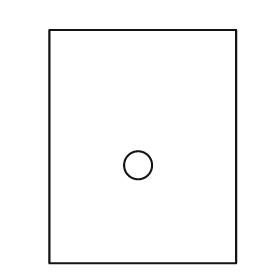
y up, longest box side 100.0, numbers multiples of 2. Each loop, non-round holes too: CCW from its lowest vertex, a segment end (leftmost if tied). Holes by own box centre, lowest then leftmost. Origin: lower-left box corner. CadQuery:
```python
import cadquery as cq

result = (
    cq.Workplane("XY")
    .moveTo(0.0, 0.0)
    .lineTo(80.0, 0.0)
    .lineTo(80.0, 100.0)
    .lineTo(0.0, 100.0)
    .close()
    .moveTo(38.0, 42.0)
    .circle(6.0)
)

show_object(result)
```